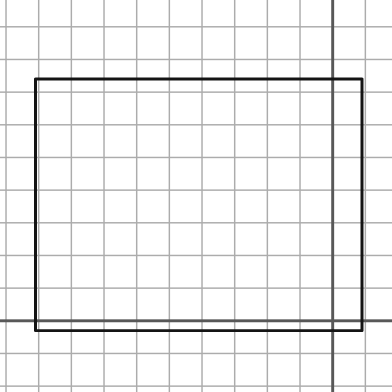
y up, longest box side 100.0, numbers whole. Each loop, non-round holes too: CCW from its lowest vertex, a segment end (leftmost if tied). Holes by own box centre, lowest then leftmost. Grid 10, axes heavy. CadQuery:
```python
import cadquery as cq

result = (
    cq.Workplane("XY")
    .moveTo(-91.0, -3.0)
    .lineTo(9.0, -3.0)
    .lineTo(9.0, 74.0)
    .lineTo(-91.0, 74.0)
    .close()
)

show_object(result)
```